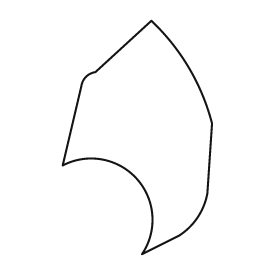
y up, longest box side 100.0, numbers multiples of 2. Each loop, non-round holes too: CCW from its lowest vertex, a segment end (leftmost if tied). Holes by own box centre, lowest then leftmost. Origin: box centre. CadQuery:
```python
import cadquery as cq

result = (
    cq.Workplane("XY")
    .moveTo(2.0, -50.0)
    .lineTo(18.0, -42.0)
    .threePointArc((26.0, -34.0), (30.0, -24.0))
    .lineTo(32.0, 6.0)
    .threePointArc((22.0, 30.0), (6.0, 50.0))
    .lineTo(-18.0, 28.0)
    .threePointArc((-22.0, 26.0), (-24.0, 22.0))
    .lineTo(-32.0, -12.0)
    .threePointArc((0.0, -18.0), (2.0, -50.0))
    .close()
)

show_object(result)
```